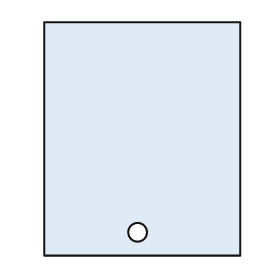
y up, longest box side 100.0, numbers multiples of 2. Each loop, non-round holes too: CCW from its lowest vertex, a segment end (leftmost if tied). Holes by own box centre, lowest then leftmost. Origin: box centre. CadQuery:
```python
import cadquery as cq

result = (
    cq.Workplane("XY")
    .moveTo(-42.0, -50.0)
    .lineTo(42.0, -50.0)
    .lineTo(42.0, 50.0)
    .lineTo(-42.0, 50.0)
    .close()
    .moveTo(-2.0, -40.0)
    .circle(4.0)
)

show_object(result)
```